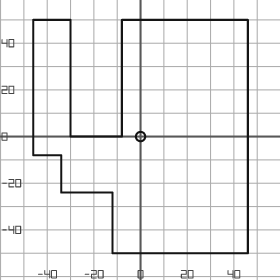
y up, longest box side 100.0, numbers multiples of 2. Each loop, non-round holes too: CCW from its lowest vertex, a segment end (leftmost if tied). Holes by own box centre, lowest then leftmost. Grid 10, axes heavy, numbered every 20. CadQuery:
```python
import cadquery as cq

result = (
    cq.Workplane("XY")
    .moveTo(-12.0, -50.0)
    .lineTo(46.0, -50.0)
    .lineTo(46.0, 50.0)
    .lineTo(-8.0, 50.0)
    .lineTo(-8.0, 0.0)
    .lineTo(-30.0, 0.0)
    .lineTo(-30.0, 50.0)
    .lineTo(-46.0, 50.0)
    .lineTo(-46.0, -8.0)
    .lineTo(-34.0, -8.0)
    .lineTo(-34.0, -24.0)
    .lineTo(-12.0, -24.0)
    .close()
    .moveTo(0.0, 0.0)
    .circle(2.0)
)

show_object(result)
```